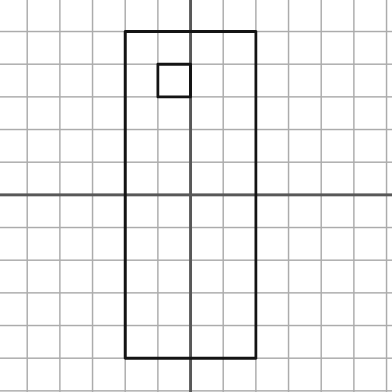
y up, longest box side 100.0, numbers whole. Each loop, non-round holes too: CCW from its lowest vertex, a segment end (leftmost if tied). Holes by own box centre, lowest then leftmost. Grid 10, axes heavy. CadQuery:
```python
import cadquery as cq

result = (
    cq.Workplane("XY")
    .moveTo(-20.0, -50.0)
    .lineTo(20.0, -50.0)
    .lineTo(20.0, 50.0)
    .lineTo(-20.0, 50.0)
    .close()
    .moveTo(-10.0, 30.0)
    .lineTo(0.0, 30.0)
    .lineTo(0.0, 40.0)
    .lineTo(-10.0, 40.0)
    .close()
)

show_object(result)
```